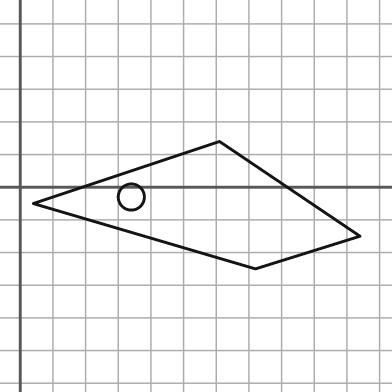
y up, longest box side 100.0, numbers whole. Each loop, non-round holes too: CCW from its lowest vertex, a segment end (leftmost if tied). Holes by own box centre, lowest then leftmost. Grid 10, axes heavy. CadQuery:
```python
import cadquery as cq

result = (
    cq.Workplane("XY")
    .moveTo(72.0, -25.0)
    .lineTo(104.0, -15.0)
    .lineTo(61.0, 14.0)
    .lineTo(4.0, -5.0)
    .close()
    .moveTo(34.0, -3.0)
    .circle(4.0)
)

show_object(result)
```